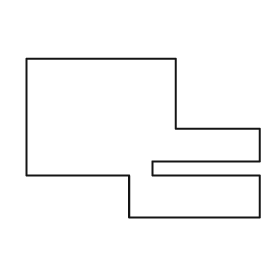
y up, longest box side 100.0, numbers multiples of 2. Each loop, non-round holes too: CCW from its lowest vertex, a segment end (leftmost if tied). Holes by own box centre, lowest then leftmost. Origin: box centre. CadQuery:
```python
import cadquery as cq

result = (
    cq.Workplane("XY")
    .moveTo(-6.0, -34.0)
    .lineTo(50.0, -34.0)
    .lineTo(50.0, -16.0)
    .lineTo(4.0, -16.0)
    .lineTo(4.0, -10.0)
    .lineTo(50.0, -10.0)
    .lineTo(50.0, 4.0)
    .lineTo(14.0, 4.0)
    .lineTo(14.0, 34.0)
    .lineTo(-50.0, 34.0)
    .lineTo(-50.0, -16.0)
    .lineTo(-6.0, -16.0)
    .close()
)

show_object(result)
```